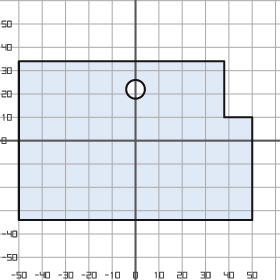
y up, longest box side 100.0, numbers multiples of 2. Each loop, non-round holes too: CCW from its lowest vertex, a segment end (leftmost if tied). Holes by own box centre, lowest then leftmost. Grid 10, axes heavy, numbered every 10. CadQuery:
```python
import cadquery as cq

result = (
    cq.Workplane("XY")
    .moveTo(-50.0, -34.0)
    .lineTo(50.0, -34.0)
    .lineTo(50.0, 10.0)
    .lineTo(38.0, 10.0)
    .lineTo(38.0, 34.0)
    .lineTo(-50.0, 34.0)
    .close()
    .moveTo(0.0, 22.0)
    .circle(4.0)
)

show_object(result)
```